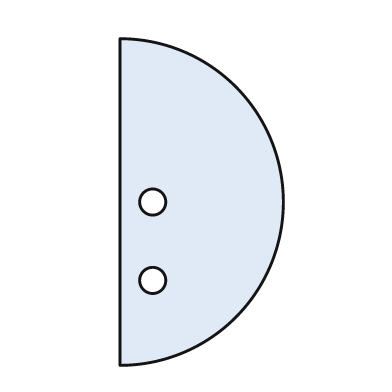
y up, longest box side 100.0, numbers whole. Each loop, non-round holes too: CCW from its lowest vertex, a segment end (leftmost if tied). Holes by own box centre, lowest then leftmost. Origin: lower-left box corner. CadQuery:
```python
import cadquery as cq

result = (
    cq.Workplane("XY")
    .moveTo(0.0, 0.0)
    .threePointArc((50.0, 50.0), (0.0, 100.0))
    .close()
    .moveTo(10.0, 26.0)
    .circle(4.0)
    .moveTo(10.0, 50.0)
    .circle(4.0)
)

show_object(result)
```